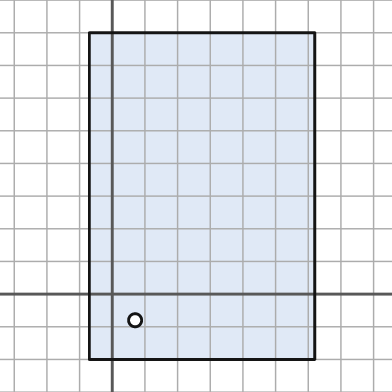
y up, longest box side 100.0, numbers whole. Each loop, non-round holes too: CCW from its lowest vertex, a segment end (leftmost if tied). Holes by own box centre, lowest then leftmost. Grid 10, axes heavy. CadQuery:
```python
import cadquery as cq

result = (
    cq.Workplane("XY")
    .moveTo(-7.0, -20.0)
    .lineTo(62.0, -20.0)
    .lineTo(62.0, 80.0)
    .lineTo(-7.0, 80.0)
    .close()
    .moveTo(7.0, -8.0)
    .circle(2.0)
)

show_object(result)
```